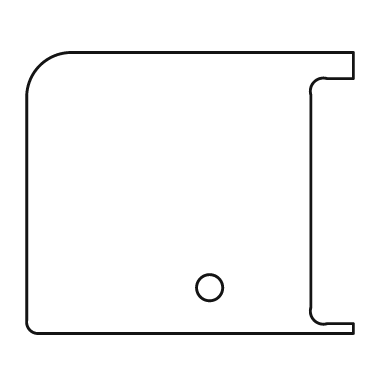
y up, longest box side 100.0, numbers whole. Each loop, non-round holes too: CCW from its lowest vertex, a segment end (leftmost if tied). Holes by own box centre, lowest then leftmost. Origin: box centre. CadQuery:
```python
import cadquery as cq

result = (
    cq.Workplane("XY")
    .moveTo(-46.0, -43.0)
    .lineTo(50.0, -43.0)
    .lineTo(50.0, -40.0)
    .lineTo(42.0, -40.0)
    .threePointArc((38.0, -39.0), (37.0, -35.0))
    .lineTo(37.0, 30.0)
    .threePointArc((38.0, 34.0), (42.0, 35.0))
    .lineTo(50.0, 35.0)
    .lineTo(50.0, 43.0)
    .lineTo(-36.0, 43.0)
    .threePointArc((-46.0, 39.0), (-50.0, 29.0))
    .lineTo(-50.0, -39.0)
    .threePointArc((-49.0, -42.0), (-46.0, -43.0))
    .close()
    .moveTo(6.0, -29.0)
    .circle(4.0)
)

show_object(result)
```